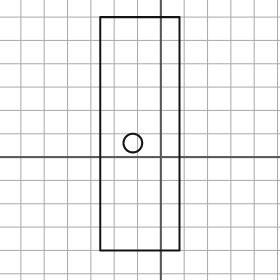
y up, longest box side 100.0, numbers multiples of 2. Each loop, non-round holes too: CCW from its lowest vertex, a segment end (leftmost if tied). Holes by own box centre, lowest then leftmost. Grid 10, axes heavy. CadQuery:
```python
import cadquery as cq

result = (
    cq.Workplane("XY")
    .moveTo(-26.0, -40.0)
    .lineTo(8.0, -40.0)
    .lineTo(8.0, 60.0)
    .lineTo(-26.0, 60.0)
    .close()
    .moveTo(-12.0, 6.0)
    .circle(4.0)
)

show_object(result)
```